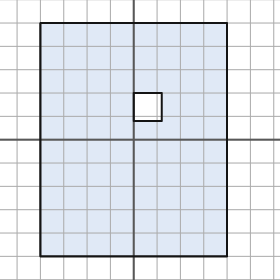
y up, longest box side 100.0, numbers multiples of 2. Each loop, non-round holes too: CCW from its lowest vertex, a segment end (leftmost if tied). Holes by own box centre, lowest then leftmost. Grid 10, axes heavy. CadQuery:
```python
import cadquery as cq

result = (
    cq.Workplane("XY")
    .moveTo(-40.0, -50.0)
    .lineTo(40.0, -50.0)
    .lineTo(40.0, 50.0)
    .lineTo(-40.0, 50.0)
    .close()
    .moveTo(0.0, 8.0)
    .lineTo(12.0, 8.0)
    .lineTo(12.0, 20.0)
    .lineTo(0.0, 20.0)
    .close()
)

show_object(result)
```